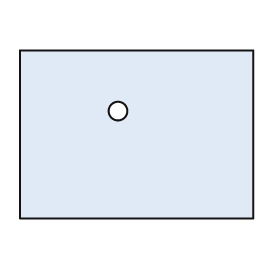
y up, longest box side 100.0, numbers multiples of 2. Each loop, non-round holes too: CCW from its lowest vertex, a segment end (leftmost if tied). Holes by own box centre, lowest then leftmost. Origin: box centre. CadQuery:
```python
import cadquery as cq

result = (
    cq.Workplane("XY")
    .moveTo(-50.0, -36.0)
    .lineTo(50.0, -36.0)
    .lineTo(50.0, 36.0)
    .lineTo(-50.0, 36.0)
    .close()
    .moveTo(-8.0, 10.0)
    .circle(4.0)
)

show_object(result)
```